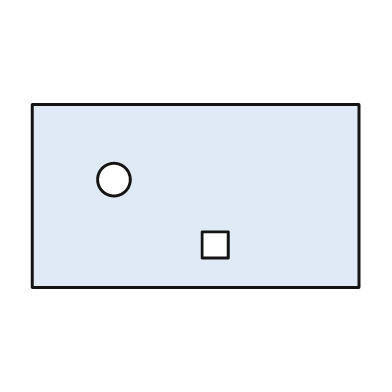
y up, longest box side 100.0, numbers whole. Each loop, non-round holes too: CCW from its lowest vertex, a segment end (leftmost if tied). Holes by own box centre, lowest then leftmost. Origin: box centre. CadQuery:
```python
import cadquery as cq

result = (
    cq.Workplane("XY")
    .moveTo(-50.0, -28.0)
    .lineTo(50.0, -28.0)
    .lineTo(50.0, 28.0)
    .lineTo(-50.0, 28.0)
    .close()
    .moveTo(2.0, -19.0)
    .lineTo(10.0, -19.0)
    .lineTo(10.0, -11.0)
    .lineTo(2.0, -11.0)
    .close()
    .moveTo(-25.0, 5.0)
    .circle(5.0)
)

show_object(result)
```